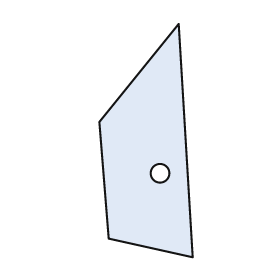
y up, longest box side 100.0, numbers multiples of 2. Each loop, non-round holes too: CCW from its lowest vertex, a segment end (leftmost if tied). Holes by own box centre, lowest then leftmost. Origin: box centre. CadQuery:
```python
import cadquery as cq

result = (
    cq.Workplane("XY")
    .moveTo(20.0, -50.0)
    .lineTo(14.0, 50.0)
    .lineTo(-20.0, 8.0)
    .lineTo(-16.0, -42.0)
    .close()
    .moveTo(6.0, -14.0)
    .circle(4.0)
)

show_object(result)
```